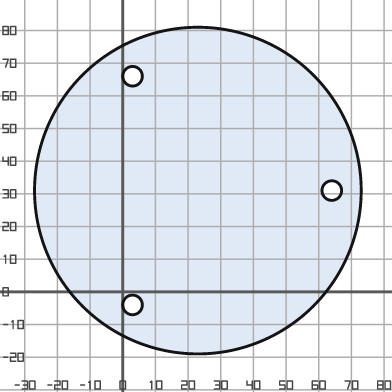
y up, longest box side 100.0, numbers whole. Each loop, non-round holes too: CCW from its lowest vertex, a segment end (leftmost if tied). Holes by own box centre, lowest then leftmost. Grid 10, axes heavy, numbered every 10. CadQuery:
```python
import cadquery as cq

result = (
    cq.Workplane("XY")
    .moveTo(23.0, 31.0)
    .circle(50.0)
    .moveTo(3.0, -4.0)
    .circle(3.0)
    .moveTo(64.0, 31.0)
    .circle(3.0)
    .moveTo(3.0, 66.0)
    .circle(3.0)
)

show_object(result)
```